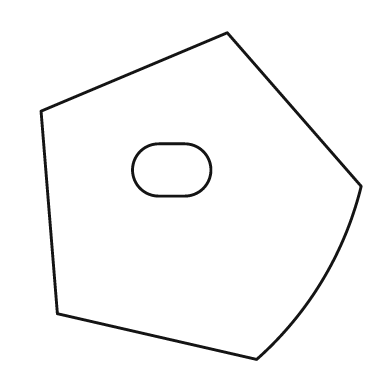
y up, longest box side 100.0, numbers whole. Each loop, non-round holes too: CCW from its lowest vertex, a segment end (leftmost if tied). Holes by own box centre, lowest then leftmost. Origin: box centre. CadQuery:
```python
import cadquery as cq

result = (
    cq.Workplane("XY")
    .moveTo(17.0, -50.0)
    .threePointArc((37.0, -26.0), (49.0, 3.0))
    .lineTo(8.0, 50.0)
    .lineTo(-49.0, 26.0)
    .lineTo(-44.0, -36.0)
    .close()
    .moveTo(-13.0, 0.0)
    .lineTo(-5.0, 0.0)
    .threePointArc((3.0, 8.0), (-5.0, 16.0))
    .lineTo(-13.0, 16.0)
    .threePointArc((-21.0, 8.0), (-13.0, 0.0))
    .close()
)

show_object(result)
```